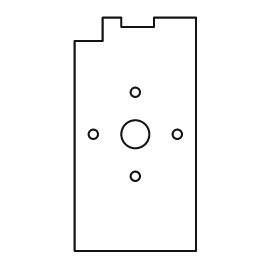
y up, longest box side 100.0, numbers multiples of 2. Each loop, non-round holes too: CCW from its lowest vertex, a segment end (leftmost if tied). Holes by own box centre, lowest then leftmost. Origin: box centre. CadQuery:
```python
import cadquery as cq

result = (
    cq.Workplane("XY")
    .moveTo(-26.0, -50.0)
    .lineTo(26.0, -50.0)
    .lineTo(26.0, 50.0)
    .lineTo(8.0, 50.0)
    .lineTo(8.0, 46.0)
    .lineTo(-6.0, 46.0)
    .lineTo(-6.0, 50.0)
    .lineTo(-14.0, 50.0)
    .lineTo(-14.0, 40.0)
    .lineTo(-26.0, 40.0)
    .close()
    .moveTo(0.0, -18.0)
    .circle(2.0)
    .moveTo(-18.0, 0.0)
    .circle(2.0)
    .moveTo(0.0, 0.0)
    .circle(6.0)
    .moveTo(18.0, 0.0)
    .circle(2.0)
    .moveTo(0.0, 18.0)
    .circle(2.0)
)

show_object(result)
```